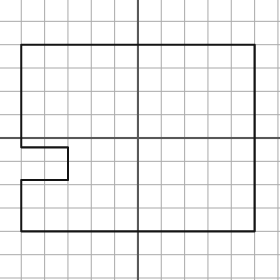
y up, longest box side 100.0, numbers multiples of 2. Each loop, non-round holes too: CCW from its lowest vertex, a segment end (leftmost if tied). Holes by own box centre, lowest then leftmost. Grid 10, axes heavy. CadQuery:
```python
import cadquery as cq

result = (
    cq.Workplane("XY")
    .moveTo(-50.0, -40.0)
    .lineTo(50.0, -40.0)
    .lineTo(50.0, 40.0)
    .lineTo(-50.0, 40.0)
    .lineTo(-50.0, -4.0)
    .lineTo(-30.0, -4.0)
    .lineTo(-30.0, -18.0)
    .lineTo(-50.0, -18.0)
    .close()
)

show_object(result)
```